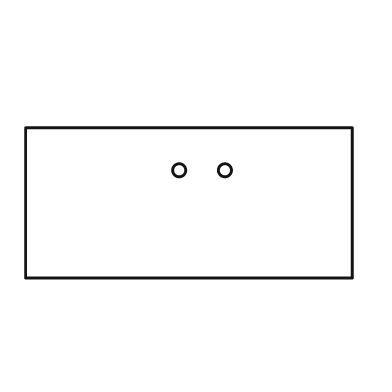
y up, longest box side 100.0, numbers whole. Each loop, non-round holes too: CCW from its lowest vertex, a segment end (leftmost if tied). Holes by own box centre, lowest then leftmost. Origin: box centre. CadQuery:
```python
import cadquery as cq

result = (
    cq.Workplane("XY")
    .moveTo(-50.0, -23.0)
    .lineTo(50.0, -23.0)
    .lineTo(50.0, 23.0)
    .lineTo(-50.0, 23.0)
    .close()
    .moveTo(-3.0, 10.0)
    .circle(2.0)
    .moveTo(11.0, 10.0)
    .circle(2.0)
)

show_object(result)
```